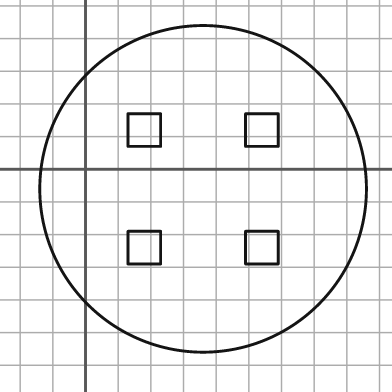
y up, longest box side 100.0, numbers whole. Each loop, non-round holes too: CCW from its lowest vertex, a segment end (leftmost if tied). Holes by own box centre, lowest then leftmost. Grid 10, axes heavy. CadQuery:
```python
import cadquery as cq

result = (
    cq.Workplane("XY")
    .moveTo(36.0, -6.0)
    .circle(50.0)
    .moveTo(13.0, -29.0)
    .lineTo(23.0, -29.0)
    .lineTo(23.0, -19.0)
    .lineTo(13.0, -19.0)
    .close()
    .moveTo(49.0, -29.0)
    .lineTo(59.0, -29.0)
    .lineTo(59.0, -19.0)
    .lineTo(49.0, -19.0)
    .close()
    .moveTo(13.0, 7.0)
    .lineTo(23.0, 7.0)
    .lineTo(23.0, 17.0)
    .lineTo(13.0, 17.0)
    .close()
    .moveTo(49.0, 7.0)
    .lineTo(59.0, 7.0)
    .lineTo(59.0, 17.0)
    .lineTo(49.0, 17.0)
    .close()
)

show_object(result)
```